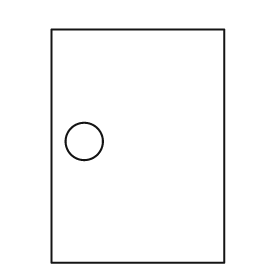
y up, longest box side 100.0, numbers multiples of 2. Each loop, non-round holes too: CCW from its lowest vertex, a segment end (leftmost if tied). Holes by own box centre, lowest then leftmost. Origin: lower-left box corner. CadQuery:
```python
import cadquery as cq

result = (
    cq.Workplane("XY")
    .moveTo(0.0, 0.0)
    .lineTo(74.0, 0.0)
    .lineTo(74.0, 100.0)
    .lineTo(0.0, 100.0)
    .close()
    .moveTo(14.0, 52.0)
    .circle(8.0)
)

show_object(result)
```